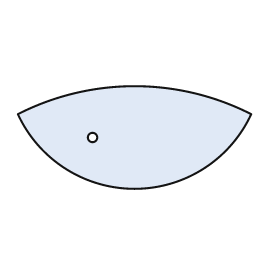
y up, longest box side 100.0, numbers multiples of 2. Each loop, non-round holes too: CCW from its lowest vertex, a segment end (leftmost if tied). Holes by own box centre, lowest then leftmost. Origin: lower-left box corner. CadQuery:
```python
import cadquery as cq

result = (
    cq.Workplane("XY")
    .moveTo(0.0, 32.0)
    .threePointArc((50.0, 0.0), (100.0, 32.0))
    .threePointArc((50.0, 44.0), (0.0, 32.0))
    .close()
    .moveTo(32.0, 22.0)
    .circle(2.0)
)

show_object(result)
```